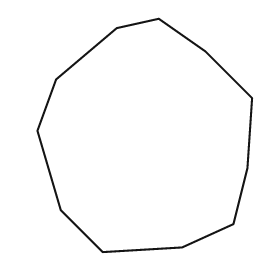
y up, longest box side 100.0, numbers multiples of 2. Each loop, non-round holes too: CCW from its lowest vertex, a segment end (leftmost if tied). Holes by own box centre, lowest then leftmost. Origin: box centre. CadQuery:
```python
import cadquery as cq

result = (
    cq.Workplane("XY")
    .moveTo(-18.0, -50.0)
    .lineTo(16.0, -48.0)
    .lineTo(38.0, -38.0)
    .lineTo(44.0, -14.0)
    .lineTo(46.0, 16.0)
    .lineTo(26.0, 36.0)
    .lineTo(6.0, 50.0)
    .lineTo(-12.0, 46.0)
    .lineTo(-38.0, 24.0)
    .lineTo(-46.0, 2.0)
    .lineTo(-36.0, -32.0)
    .close()
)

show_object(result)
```